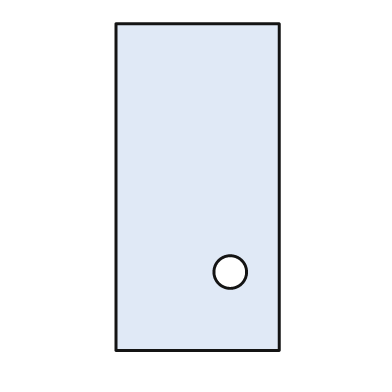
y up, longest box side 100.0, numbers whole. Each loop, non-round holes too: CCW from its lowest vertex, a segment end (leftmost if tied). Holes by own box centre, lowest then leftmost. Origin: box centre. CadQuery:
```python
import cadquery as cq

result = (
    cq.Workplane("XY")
    .moveTo(-25.0, -50.0)
    .lineTo(25.0, -50.0)
    .lineTo(25.0, 50.0)
    .lineTo(-25.0, 50.0)
    .close()
    .moveTo(10.0, -26.0)
    .circle(5.0)
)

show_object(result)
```